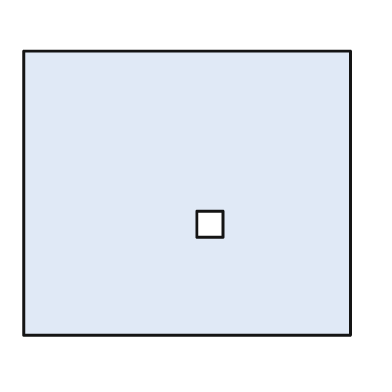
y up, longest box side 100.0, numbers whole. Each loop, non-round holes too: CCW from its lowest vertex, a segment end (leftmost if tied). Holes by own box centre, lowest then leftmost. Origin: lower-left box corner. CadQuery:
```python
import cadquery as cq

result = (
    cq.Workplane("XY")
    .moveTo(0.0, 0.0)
    .lineTo(100.0, 0.0)
    .lineTo(100.0, 87.0)
    .lineTo(0.0, 87.0)
    .close()
    .moveTo(53.0, 30.0)
    .lineTo(61.0, 30.0)
    .lineTo(61.0, 38.0)
    .lineTo(53.0, 38.0)
    .close()
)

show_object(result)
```